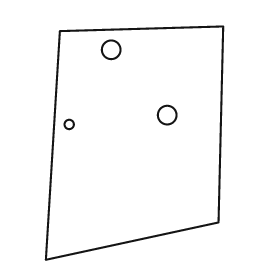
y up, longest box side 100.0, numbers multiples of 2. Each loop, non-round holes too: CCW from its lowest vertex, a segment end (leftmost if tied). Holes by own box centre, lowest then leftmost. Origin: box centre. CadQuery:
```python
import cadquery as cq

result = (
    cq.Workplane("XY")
    .moveTo(-38.0, -50.0)
    .lineTo(36.0, -34.0)
    .lineTo(38.0, 50.0)
    .lineTo(-32.0, 48.0)
    .close()
    .moveTo(-28.0, 8.0)
    .circle(2.0)
    .moveTo(14.0, 12.0)
    .circle(4.0)
    .moveTo(-10.0, 40.0)
    .circle(4.0)
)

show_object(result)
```